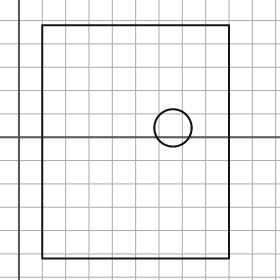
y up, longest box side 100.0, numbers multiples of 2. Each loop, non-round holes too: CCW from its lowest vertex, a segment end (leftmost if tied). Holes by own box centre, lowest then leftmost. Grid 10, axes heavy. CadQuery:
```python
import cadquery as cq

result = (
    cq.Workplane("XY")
    .moveTo(10.0, -52.0)
    .lineTo(90.0, -52.0)
    .lineTo(90.0, 48.0)
    .lineTo(10.0, 48.0)
    .close()
    .moveTo(66.0, 4.0)
    .circle(8.0)
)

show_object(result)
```